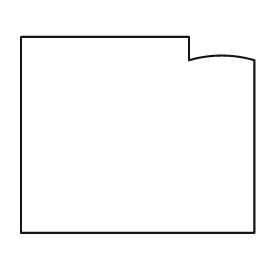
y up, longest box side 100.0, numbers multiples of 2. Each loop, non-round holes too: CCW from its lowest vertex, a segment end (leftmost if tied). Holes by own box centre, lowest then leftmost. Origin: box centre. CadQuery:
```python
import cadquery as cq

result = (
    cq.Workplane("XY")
    .moveTo(-50.0, -42.0)
    .lineTo(50.0, -42.0)
    .lineTo(50.0, 32.0)
    .threePointArc((36.0, 34.0), (22.0, 32.0))
    .lineTo(22.0, 42.0)
    .lineTo(-50.0, 42.0)
    .close()
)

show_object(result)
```